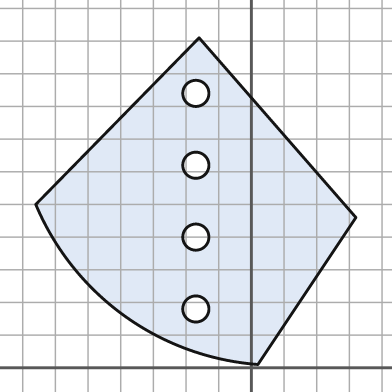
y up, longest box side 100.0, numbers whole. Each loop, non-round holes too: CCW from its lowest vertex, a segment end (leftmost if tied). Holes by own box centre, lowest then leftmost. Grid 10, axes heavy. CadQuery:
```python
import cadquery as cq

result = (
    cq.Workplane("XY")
    .moveTo(2.0, 1.0)
    .lineTo(32.0, 46.0)
    .lineTo(-16.0, 101.0)
    .lineTo(-66.0, 50.0)
    .threePointArc((-39.0, 16.0), (2.0, 1.0))
    .close()
    .moveTo(-17.0, 18.0)
    .circle(4.0)
    .moveTo(-17.0, 40.0)
    .circle(4.0)
    .moveTo(-17.0, 62.0)
    .circle(4.0)
    .moveTo(-17.0, 84.0)
    .circle(4.0)
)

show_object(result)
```